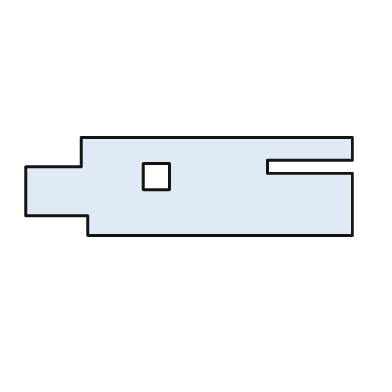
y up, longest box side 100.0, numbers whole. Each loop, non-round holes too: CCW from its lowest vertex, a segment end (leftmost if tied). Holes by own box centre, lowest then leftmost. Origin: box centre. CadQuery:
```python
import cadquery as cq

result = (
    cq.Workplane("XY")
    .moveTo(-31.0, -15.0)
    .lineTo(50.0, -15.0)
    .lineTo(50.0, 4.0)
    .lineTo(24.0, 4.0)
    .lineTo(24.0, 8.0)
    .lineTo(50.0, 8.0)
    .lineTo(50.0, 15.0)
    .lineTo(-33.0, 15.0)
    .lineTo(-33.0, 6.0)
    .lineTo(-50.0, 6.0)
    .lineTo(-50.0, -9.0)
    .lineTo(-31.0, -9.0)
    .close()
    .moveTo(-14.0, -1.0)
    .lineTo(-6.0, -1.0)
    .lineTo(-6.0, 7.0)
    .lineTo(-14.0, 7.0)
    .close()
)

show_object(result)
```